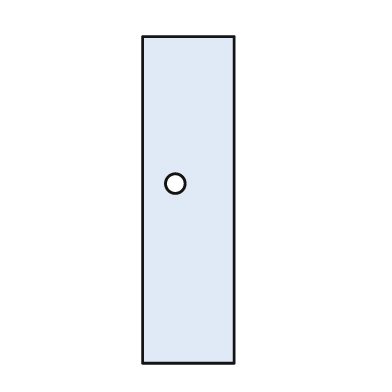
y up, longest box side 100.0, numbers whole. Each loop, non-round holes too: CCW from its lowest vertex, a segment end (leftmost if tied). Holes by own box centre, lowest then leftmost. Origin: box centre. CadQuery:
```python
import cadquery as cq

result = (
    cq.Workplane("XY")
    .moveTo(-14.0, -50.0)
    .lineTo(14.0, -50.0)
    .lineTo(14.0, 50.0)
    .lineTo(-14.0, 50.0)
    .close()
    .moveTo(-4.0, 5.0)
    .circle(3.0)
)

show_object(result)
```